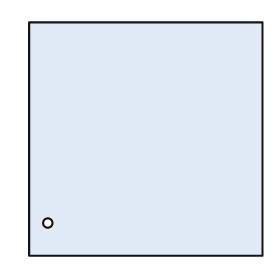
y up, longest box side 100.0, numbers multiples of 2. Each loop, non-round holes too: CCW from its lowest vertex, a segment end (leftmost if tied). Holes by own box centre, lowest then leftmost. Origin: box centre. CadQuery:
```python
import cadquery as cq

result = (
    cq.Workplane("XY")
    .moveTo(-50.0, -50.0)
    .lineTo(50.0, -50.0)
    .lineTo(50.0, 50.0)
    .lineTo(-50.0, 50.0)
    .close()
    .moveTo(-42.0, -36.0)
    .circle(2.0)
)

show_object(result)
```